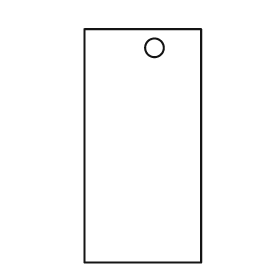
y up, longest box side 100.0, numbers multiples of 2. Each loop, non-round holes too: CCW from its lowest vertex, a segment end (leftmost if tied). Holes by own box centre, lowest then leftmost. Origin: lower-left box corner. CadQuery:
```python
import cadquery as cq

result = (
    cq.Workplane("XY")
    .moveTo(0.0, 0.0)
    .lineTo(50.0, 0.0)
    .lineTo(50.0, 100.0)
    .lineTo(0.0, 100.0)
    .close()
    .moveTo(30.0, 92.0)
    .circle(4.0)
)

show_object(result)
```